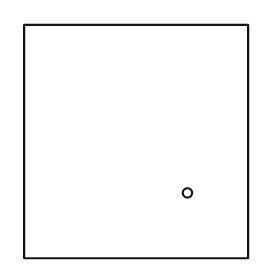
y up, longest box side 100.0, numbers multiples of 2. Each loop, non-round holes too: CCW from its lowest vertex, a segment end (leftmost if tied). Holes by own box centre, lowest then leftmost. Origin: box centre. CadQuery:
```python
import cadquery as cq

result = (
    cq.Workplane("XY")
    .moveTo(-48.0, -50.0)
    .lineTo(48.0, -50.0)
    .lineTo(48.0, 50.0)
    .lineTo(-48.0, 50.0)
    .close()
    .moveTo(22.0, -22.0)
    .circle(2.0)
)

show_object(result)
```